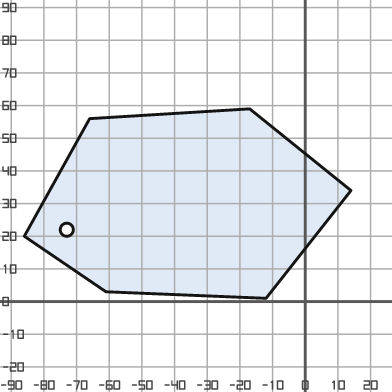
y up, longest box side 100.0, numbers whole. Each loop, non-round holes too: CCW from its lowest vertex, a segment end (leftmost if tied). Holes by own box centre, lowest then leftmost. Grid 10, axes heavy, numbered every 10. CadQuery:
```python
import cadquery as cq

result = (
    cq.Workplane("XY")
    .moveTo(-12.0, 1.0)
    .lineTo(14.0, 34.0)
    .lineTo(-17.0, 59.0)
    .lineTo(-66.0, 56.0)
    .lineTo(-86.0, 20.0)
    .lineTo(-61.0, 3.0)
    .close()
    .moveTo(-73.0, 22.0)
    .circle(2.0)
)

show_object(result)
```